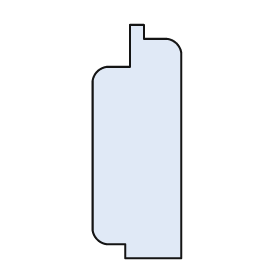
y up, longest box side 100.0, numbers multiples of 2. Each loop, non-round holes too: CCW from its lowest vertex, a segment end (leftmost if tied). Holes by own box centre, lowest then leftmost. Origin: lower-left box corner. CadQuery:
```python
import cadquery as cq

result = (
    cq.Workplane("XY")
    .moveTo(14.0, 0.0)
    .lineTo(38.0, 0.0)
    .lineTo(38.0, 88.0)
    .threePointArc((36.0, 92.0), (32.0, 94.0))
    .lineTo(22.0, 94.0)
    .lineTo(22.0, 100.0)
    .lineTo(16.0, 100.0)
    .lineTo(16.0, 82.0)
    .lineTo(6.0, 82.0)
    .threePointArc((2.0, 80.0), (0.0, 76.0))
    .lineTo(0.0, 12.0)
    .threePointArc((2.0, 8.0), (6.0, 6.0))
    .lineTo(14.0, 6.0)
    .close()
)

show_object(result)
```